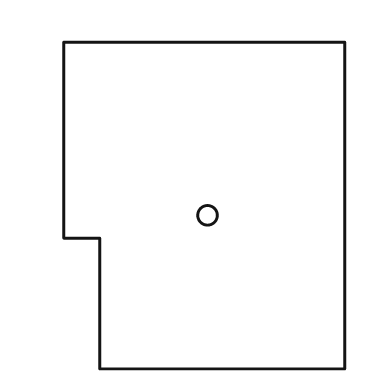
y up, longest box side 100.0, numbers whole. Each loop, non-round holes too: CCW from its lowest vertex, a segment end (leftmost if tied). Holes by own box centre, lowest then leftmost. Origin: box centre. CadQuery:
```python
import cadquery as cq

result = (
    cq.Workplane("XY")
    .moveTo(-32.0, -50.0)
    .lineTo(43.0, -50.0)
    .lineTo(43.0, 50.0)
    .lineTo(-43.0, 50.0)
    .lineTo(-43.0, -10.0)
    .lineTo(-32.0, -10.0)
    .close()
    .moveTo(1.0, -3.0)
    .circle(3.0)
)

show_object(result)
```